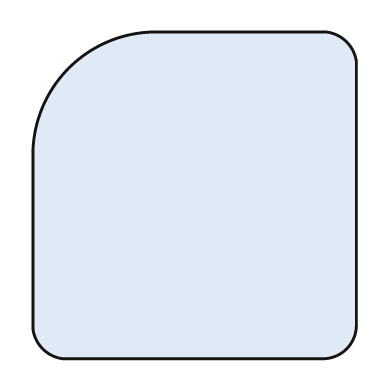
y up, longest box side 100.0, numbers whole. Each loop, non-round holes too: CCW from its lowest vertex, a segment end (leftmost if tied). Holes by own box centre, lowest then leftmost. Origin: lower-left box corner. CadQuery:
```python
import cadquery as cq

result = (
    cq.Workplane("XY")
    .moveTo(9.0, 0.0)
    .lineTo(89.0, 0.0)
    .threePointArc((96.0, 3.0), (99.0, 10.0))
    .lineTo(99.0, 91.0)
    .threePointArc((96.0, 97.0), (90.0, 100.0))
    .lineTo(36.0, 100.0)
    .threePointArc((11.0, 89.0), (0.0, 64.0))
    .lineTo(0.0, 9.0)
    .threePointArc((3.0, 3.0), (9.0, 0.0))
    .close()
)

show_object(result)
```